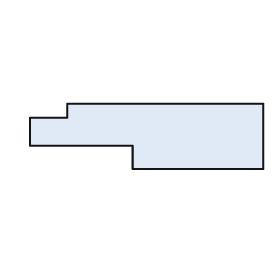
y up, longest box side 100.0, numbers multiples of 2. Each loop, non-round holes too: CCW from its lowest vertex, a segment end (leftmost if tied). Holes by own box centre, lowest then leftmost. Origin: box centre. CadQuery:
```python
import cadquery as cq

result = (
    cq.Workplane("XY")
    .moveTo(-6.0, -14.0)
    .lineTo(50.0, -14.0)
    .lineTo(50.0, 14.0)
    .lineTo(-34.0, 14.0)
    .lineTo(-34.0, 8.0)
    .lineTo(-50.0, 8.0)
    .lineTo(-50.0, -4.0)
    .lineTo(-6.0, -4.0)
    .close()
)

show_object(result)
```